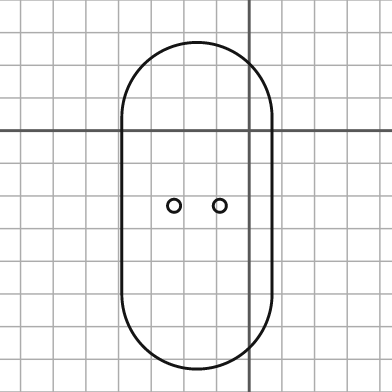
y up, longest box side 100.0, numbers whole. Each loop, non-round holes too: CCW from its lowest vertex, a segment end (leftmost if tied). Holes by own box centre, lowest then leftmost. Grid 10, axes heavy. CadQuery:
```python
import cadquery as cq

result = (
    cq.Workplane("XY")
    .moveTo(-39.0, -50.0)
    .threePointArc((-16.0, -73.0), (7.0, -50.0))
    .lineTo(7.0, 4.0)
    .threePointArc((-16.0, 27.0), (-39.0, 4.0))
    .close()
    .moveTo(-23.0, -23.0)
    .circle(2.0)
    .moveTo(-9.0, -23.0)
    .circle(2.0)
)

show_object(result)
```